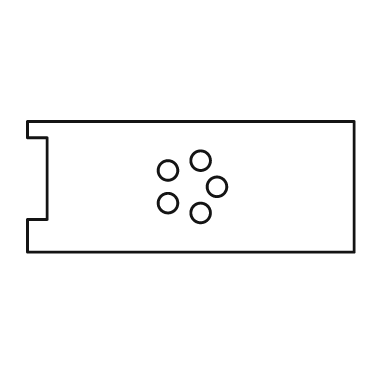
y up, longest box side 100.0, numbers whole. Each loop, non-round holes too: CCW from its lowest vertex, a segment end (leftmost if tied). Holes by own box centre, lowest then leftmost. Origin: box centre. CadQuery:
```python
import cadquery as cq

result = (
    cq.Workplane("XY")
    .moveTo(-50.0, -20.0)
    .lineTo(50.0, -20.0)
    .lineTo(50.0, 20.0)
    .lineTo(-50.0, 20.0)
    .lineTo(-50.0, 15.0)
    .lineTo(-44.0, 15.0)
    .lineTo(-44.0, -10.0)
    .lineTo(-50.0, -10.0)
    .close()
    .moveTo(3.0, -8.0)
    .circle(3.0)
    .moveTo(-7.0, -5.0)
    .circle(3.0)
    .moveTo(8.0, 0.0)
    .circle(3.0)
    .moveTo(-7.0, 5.0)
    .circle(3.0)
    .moveTo(3.0, 8.0)
    .circle(3.0)
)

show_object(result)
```